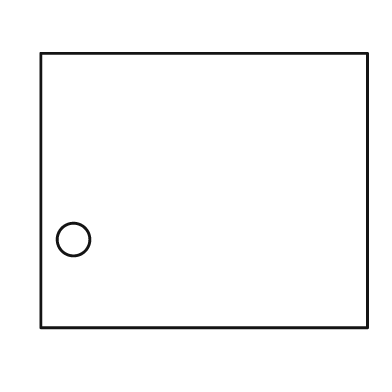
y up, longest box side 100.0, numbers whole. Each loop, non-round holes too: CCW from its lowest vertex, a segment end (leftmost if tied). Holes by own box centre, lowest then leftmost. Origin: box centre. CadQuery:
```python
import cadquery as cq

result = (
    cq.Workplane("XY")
    .moveTo(-50.0, -42.0)
    .lineTo(50.0, -42.0)
    .lineTo(50.0, 42.0)
    .lineTo(-50.0, 42.0)
    .close()
    .moveTo(-40.0, -15.0)
    .circle(5.0)
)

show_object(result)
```